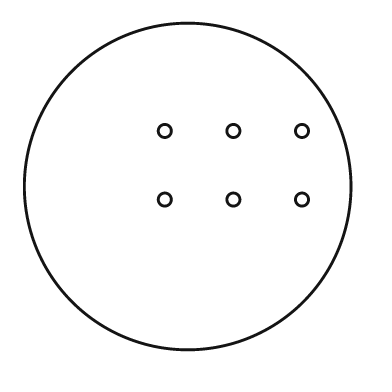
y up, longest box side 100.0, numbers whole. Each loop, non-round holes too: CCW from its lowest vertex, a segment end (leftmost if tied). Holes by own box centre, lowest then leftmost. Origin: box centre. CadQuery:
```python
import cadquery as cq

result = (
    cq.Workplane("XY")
    .moveTo(0.0, 0.0)
    .circle(50.0)
    .moveTo(-7.0, -4.0)
    .circle(2.0)
    .moveTo(14.0, -4.0)
    .circle(2.0)
    .moveTo(35.0, -4.0)
    .circle(2.0)
    .moveTo(-7.0, 17.0)
    .circle(2.0)
    .moveTo(14.0, 17.0)
    .circle(2.0)
    .moveTo(35.0, 17.0)
    .circle(2.0)
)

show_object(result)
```